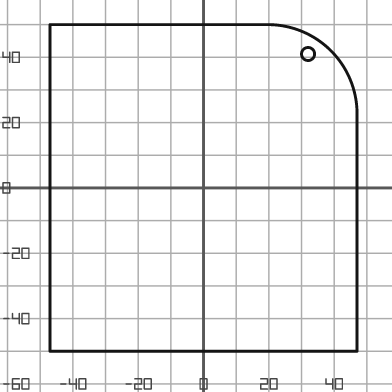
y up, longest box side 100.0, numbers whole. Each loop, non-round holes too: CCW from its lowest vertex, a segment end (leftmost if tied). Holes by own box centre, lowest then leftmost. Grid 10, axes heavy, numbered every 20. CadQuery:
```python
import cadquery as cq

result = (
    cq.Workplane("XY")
    .moveTo(-47.0, -50.0)
    .lineTo(47.0, -50.0)
    .lineTo(47.0, 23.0)
    .threePointArc((39.0, 42.0), (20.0, 50.0))
    .lineTo(-47.0, 50.0)
    .close()
    .moveTo(32.0, 41.0)
    .circle(2.0)
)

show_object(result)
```